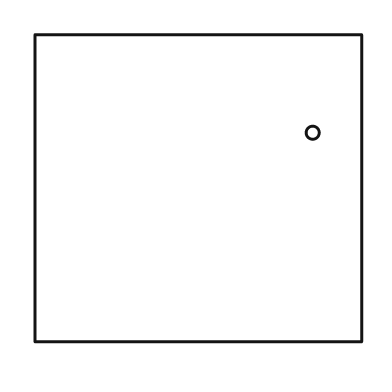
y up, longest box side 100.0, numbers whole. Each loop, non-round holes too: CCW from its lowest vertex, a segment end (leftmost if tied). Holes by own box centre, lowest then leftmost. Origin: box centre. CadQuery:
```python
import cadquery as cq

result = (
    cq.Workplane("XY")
    .moveTo(-50.0, -47.0)
    .lineTo(50.0, -47.0)
    .lineTo(50.0, 47.0)
    .lineTo(-50.0, 47.0)
    .close()
    .moveTo(35.0, 17.0)
    .circle(2.0)
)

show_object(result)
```